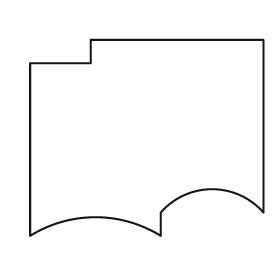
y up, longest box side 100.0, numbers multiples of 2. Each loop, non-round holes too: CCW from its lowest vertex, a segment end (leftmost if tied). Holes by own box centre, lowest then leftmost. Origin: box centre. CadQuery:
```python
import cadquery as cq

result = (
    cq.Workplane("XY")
    .moveTo(-50.0, -42.0)
    .threePointArc((-22.0, -34.0), (6.0, -42.0))
    .lineTo(6.0, -32.0)
    .threePointArc((28.0, -22.0), (50.0, -32.0))
    .lineTo(50.0, 42.0)
    .lineTo(-24.0, 42.0)
    .lineTo(-24.0, 32.0)
    .lineTo(-50.0, 32.0)
    .close()
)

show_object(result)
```